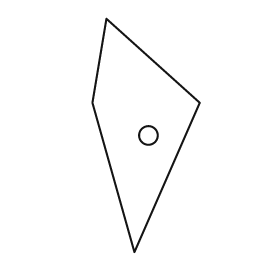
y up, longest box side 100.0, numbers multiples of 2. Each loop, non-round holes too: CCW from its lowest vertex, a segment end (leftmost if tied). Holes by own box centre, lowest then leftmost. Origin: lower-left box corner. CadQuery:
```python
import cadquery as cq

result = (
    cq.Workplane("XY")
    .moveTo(18.0, 0.0)
    .lineTo(46.0, 64.0)
    .lineTo(6.0, 100.0)
    .lineTo(0.0, 64.0)
    .close()
    .moveTo(24.0, 50.0)
    .circle(4.0)
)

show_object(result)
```